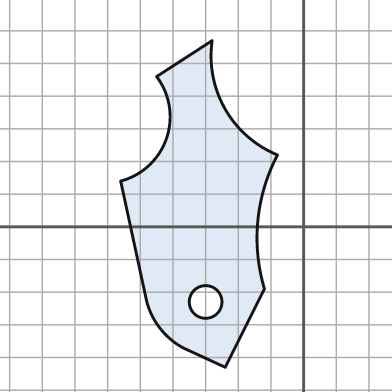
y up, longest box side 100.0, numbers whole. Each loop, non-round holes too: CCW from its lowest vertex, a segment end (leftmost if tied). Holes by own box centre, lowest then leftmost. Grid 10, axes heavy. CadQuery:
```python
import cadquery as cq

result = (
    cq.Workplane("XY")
    .moveTo(-24.0, -43.0)
    .lineTo(-12.0, -19.0)
    .threePointArc((-14.0, 2.0), (-8.0, 22.0))
    .threePointArc((-24.0, 36.0), (-28.0, 57.0))
    .lineTo(-45.0, 46.0)
    .threePointArc((-42.0, 27.0), (-56.0, 14.0))
    .lineTo(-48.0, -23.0)
    .threePointArc((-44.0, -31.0), (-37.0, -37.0))
    .close()
    .moveTo(-30.0, -23.0)
    .circle(5.0)
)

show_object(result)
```